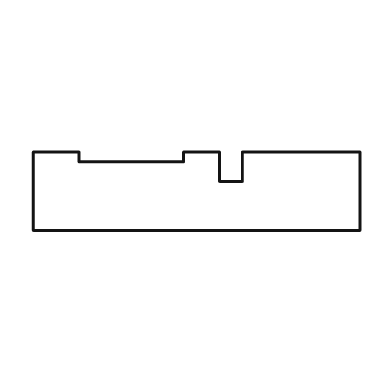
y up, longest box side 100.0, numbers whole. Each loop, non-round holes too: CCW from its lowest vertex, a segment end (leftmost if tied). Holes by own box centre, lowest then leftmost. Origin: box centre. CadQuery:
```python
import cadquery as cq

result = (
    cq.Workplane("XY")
    .moveTo(-50.0, -12.0)
    .lineTo(50.0, -12.0)
    .lineTo(50.0, 12.0)
    .lineTo(14.0, 12.0)
    .lineTo(14.0, 3.0)
    .lineTo(7.0, 3.0)
    .lineTo(7.0, 12.0)
    .lineTo(-4.0, 12.0)
    .lineTo(-4.0, 9.0)
    .lineTo(-36.0, 9.0)
    .lineTo(-36.0, 12.0)
    .lineTo(-50.0, 12.0)
    .close()
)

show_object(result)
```